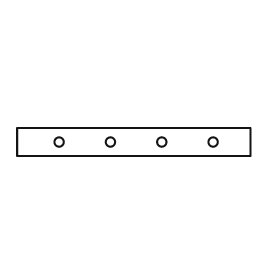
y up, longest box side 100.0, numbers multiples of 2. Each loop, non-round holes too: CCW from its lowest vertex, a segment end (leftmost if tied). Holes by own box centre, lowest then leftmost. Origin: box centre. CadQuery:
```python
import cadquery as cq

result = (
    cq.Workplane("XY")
    .moveTo(-50.0, -6.0)
    .lineTo(50.0, -6.0)
    .lineTo(50.0, 6.0)
    .lineTo(-50.0, 6.0)
    .close()
    .moveTo(-32.0, 0.0)
    .circle(2.0)
    .moveTo(-10.0, 0.0)
    .circle(2.0)
    .moveTo(12.0, 0.0)
    .circle(2.0)
    .moveTo(34.0, 0.0)
    .circle(2.0)
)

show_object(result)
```